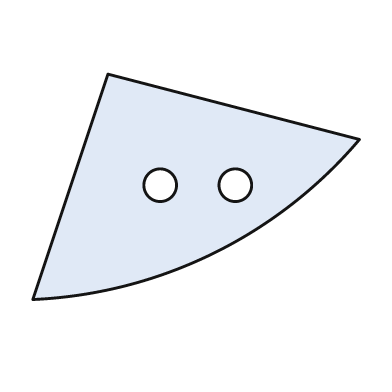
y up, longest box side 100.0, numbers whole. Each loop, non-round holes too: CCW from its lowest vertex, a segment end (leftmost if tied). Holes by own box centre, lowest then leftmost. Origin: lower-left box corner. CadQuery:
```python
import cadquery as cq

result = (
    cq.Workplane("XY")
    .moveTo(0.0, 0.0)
    .threePointArc((55.0, 14.0), (100.0, 49.0))
    .lineTo(23.0, 69.0)
    .close()
    .moveTo(39.0, 35.0)
    .circle(5.0)
    .moveTo(62.0, 35.0)
    .circle(5.0)
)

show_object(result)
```